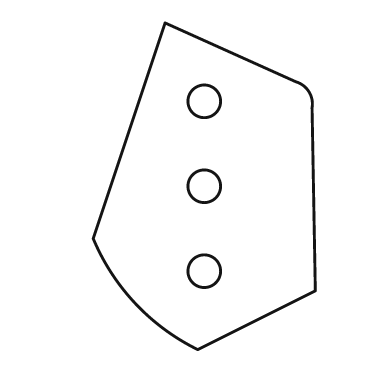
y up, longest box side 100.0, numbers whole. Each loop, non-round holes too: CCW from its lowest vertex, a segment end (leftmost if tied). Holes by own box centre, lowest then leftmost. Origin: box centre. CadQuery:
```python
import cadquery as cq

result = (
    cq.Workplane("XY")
    .moveTo(-2.0, -50.0)
    .lineTo(34.0, -32.0)
    .lineTo(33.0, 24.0)
    .threePointArc((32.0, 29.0), (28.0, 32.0))
    .lineTo(-12.0, 50.0)
    .lineTo(-34.0, -16.0)
    .threePointArc((-21.0, -36.0), (-2.0, -50.0))
    .close()
    .moveTo(0.0, -26.0)
    .circle(5.0)
    .moveTo(0.0, 0.0)
    .circle(5.0)
    .moveTo(0.0, 26.0)
    .circle(5.0)
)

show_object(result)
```